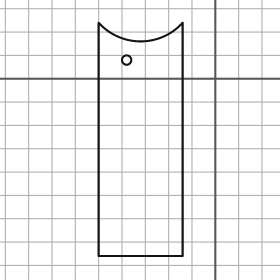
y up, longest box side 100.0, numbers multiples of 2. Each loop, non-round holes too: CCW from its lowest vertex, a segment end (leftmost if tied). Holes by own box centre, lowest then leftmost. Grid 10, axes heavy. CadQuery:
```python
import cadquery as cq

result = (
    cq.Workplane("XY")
    .moveTo(-50.0, -76.0)
    .lineTo(-14.0, -76.0)
    .lineTo(-14.0, 24.0)
    .threePointArc((-32.0, 16.0), (-50.0, 24.0))
    .close()
    .moveTo(-38.0, 8.0)
    .circle(2.0)
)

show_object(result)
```